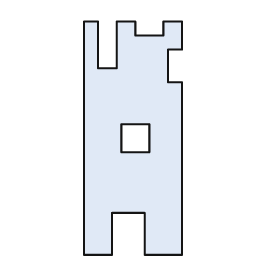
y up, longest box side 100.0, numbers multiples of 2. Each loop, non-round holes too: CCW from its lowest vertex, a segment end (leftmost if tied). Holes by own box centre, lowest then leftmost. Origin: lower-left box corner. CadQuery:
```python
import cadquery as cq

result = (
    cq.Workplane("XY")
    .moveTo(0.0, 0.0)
    .lineTo(12.0, 0.0)
    .lineTo(12.0, 18.0)
    .lineTo(26.0, 18.0)
    .lineTo(26.0, 0.0)
    .lineTo(42.0, 0.0)
    .lineTo(42.0, 74.0)
    .lineTo(36.0, 74.0)
    .lineTo(36.0, 88.0)
    .lineTo(42.0, 88.0)
    .lineTo(42.0, 100.0)
    .lineTo(34.0, 100.0)
    .lineTo(34.0, 94.0)
    .lineTo(22.0, 94.0)
    .lineTo(22.0, 100.0)
    .lineTo(14.0, 100.0)
    .lineTo(14.0, 80.0)
    .lineTo(6.0, 80.0)
    .lineTo(6.0, 100.0)
    .lineTo(0.0, 100.0)
    .close()
    .moveTo(16.0, 44.0)
    .lineTo(28.0, 44.0)
    .lineTo(28.0, 56.0)
    .lineTo(16.0, 56.0)
    .close()
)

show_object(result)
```